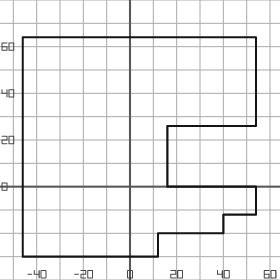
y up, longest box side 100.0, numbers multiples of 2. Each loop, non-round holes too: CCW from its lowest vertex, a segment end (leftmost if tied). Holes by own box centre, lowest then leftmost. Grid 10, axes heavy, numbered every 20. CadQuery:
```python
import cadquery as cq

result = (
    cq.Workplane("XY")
    .moveTo(-46.0, -30.0)
    .lineTo(12.0, -30.0)
    .lineTo(12.0, -20.0)
    .lineTo(40.0, -20.0)
    .lineTo(40.0, -12.0)
    .lineTo(54.0, -12.0)
    .lineTo(54.0, 0.0)
    .lineTo(16.0, 0.0)
    .lineTo(16.0, 26.0)
    .lineTo(54.0, 26.0)
    .lineTo(54.0, 64.0)
    .lineTo(-46.0, 64.0)
    .close()
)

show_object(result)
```